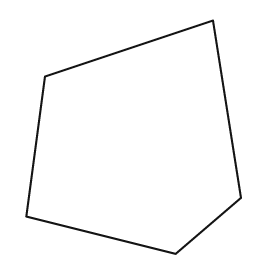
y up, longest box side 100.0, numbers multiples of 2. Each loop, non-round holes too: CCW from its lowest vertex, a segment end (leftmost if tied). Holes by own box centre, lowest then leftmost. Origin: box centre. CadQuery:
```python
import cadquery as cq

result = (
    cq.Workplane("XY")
    .moveTo(18.0, -50.0)
    .lineTo(46.0, -26.0)
    .lineTo(34.0, 50.0)
    .lineTo(-38.0, 26.0)
    .lineTo(-46.0, -34.0)
    .close()
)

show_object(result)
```